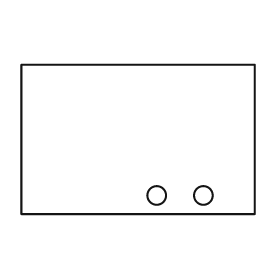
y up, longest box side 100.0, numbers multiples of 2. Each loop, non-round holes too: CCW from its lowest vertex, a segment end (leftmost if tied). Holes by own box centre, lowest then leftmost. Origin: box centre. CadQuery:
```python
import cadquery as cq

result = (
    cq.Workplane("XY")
    .moveTo(-50.0, -32.0)
    .lineTo(50.0, -32.0)
    .lineTo(50.0, 32.0)
    .lineTo(-50.0, 32.0)
    .close()
    .moveTo(8.0, -24.0)
    .circle(4.0)
    .moveTo(28.0, -24.0)
    .circle(4.0)
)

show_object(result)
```